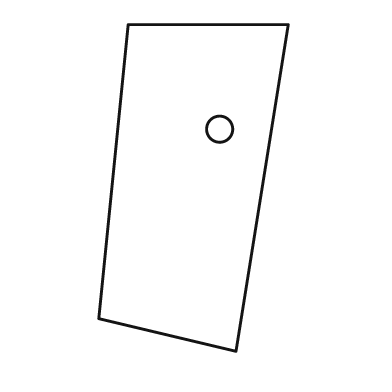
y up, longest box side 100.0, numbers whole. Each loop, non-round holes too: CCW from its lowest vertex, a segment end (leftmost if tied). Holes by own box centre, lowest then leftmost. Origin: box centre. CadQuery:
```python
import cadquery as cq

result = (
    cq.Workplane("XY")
    .moveTo(13.0, -50.0)
    .lineTo(29.0, 50.0)
    .lineTo(-20.0, 50.0)
    .lineTo(-29.0, -40.0)
    .close()
    .moveTo(8.0, 18.0)
    .circle(4.0)
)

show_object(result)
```